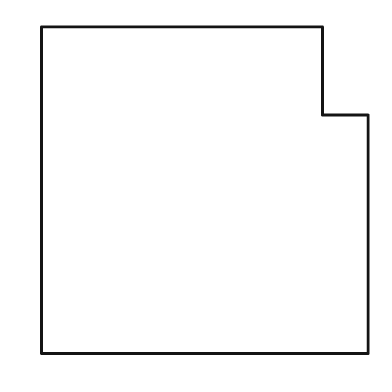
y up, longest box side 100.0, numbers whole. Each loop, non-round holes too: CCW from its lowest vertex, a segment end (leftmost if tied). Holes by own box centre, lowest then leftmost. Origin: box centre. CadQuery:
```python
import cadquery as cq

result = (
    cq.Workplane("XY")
    .moveTo(-50.0, -50.0)
    .lineTo(50.0, -50.0)
    .lineTo(50.0, 23.0)
    .lineTo(36.0, 23.0)
    .lineTo(36.0, 50.0)
    .lineTo(-50.0, 50.0)
    .close()
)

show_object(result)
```